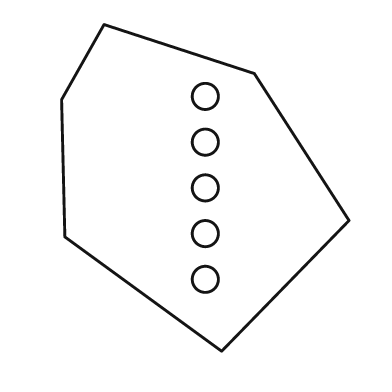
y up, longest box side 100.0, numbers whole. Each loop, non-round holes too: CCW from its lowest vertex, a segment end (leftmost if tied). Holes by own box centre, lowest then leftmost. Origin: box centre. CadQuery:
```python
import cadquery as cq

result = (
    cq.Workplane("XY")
    .moveTo(5.0, -50.0)
    .lineTo(44.0, -10.0)
    .lineTo(15.0, 35.0)
    .lineTo(-31.0, 50.0)
    .lineTo(-44.0, 27.0)
    .lineTo(-43.0, -15.0)
    .close()
    .moveTo(0.0, -28.0)
    .circle(4.0)
    .moveTo(0.0, -14.0)
    .circle(4.0)
    .moveTo(0.0, 0.0)
    .circle(4.0)
    .moveTo(0.0, 14.0)
    .circle(4.0)
    .moveTo(0.0, 28.0)
    .circle(4.0)
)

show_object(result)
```